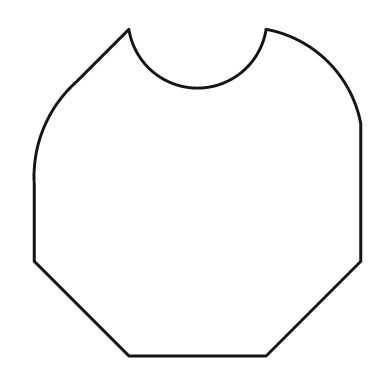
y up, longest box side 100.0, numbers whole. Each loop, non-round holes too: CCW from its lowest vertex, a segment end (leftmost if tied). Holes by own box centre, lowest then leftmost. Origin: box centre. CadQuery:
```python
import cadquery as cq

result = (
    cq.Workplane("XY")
    .moveTo(-21.0, -50.0)
    .lineTo(21.0, -50.0)
    .lineTo(50.0, -21.0)
    .lineTo(50.0, 21.0)
    .threePointArc((40.0, 40.0), (21.0, 50.0))
    .threePointArc((0.0, 32.0), (-21.0, 50.0))
    .lineTo(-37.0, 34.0)
    .threePointArc((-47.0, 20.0), (-50.0, 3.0))
    .lineTo(-50.0, -21.0)
    .close()
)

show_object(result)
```